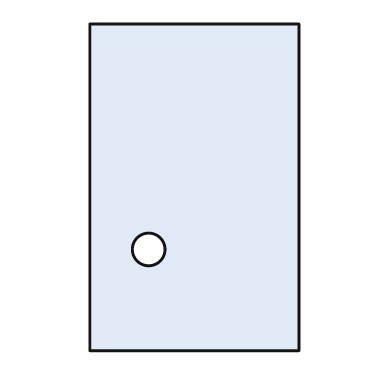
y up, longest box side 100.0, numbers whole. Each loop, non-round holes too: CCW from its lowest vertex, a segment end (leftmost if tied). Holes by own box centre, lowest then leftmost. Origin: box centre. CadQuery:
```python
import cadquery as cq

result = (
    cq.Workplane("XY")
    .moveTo(-32.0, -50.0)
    .lineTo(32.0, -50.0)
    .lineTo(32.0, 50.0)
    .lineTo(-32.0, 50.0)
    .close()
    .moveTo(-14.0, -19.0)
    .circle(5.0)
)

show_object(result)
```